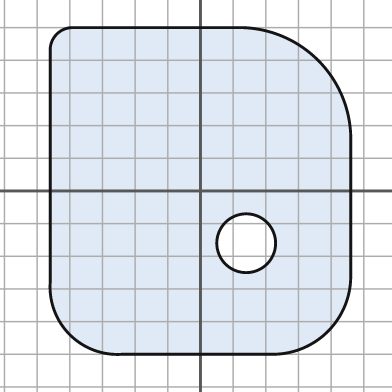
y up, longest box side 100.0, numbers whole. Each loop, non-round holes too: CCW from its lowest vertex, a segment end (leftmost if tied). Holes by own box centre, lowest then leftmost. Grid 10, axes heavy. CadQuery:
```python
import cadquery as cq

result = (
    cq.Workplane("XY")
    .moveTo(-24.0, -50.0)
    .lineTo(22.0, -50.0)
    .threePointArc((39.0, -43.0), (46.0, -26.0))
    .lineTo(46.0, 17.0)
    .threePointArc((36.0, 40.0), (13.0, 50.0))
    .lineTo(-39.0, 50.0)
    .threePointArc((-44.0, 48.0), (-46.0, 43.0))
    .lineTo(-46.0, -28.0)
    .threePointArc((-40.0, -44.0), (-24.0, -50.0))
    .close()
    .moveTo(14.0, -16.0)
    .circle(9.0)
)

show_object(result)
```